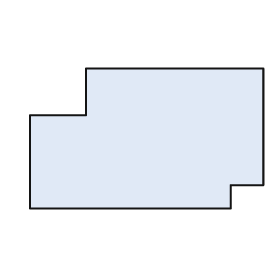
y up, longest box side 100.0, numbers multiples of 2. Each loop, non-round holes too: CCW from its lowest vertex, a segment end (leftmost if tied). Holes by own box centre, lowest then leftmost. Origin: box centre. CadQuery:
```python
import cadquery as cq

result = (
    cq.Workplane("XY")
    .moveTo(-50.0, -30.0)
    .lineTo(36.0, -30.0)
    .lineTo(36.0, -20.0)
    .lineTo(50.0, -20.0)
    .lineTo(50.0, 30.0)
    .lineTo(-26.0, 30.0)
    .lineTo(-26.0, 10.0)
    .lineTo(-50.0, 10.0)
    .close()
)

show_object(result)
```